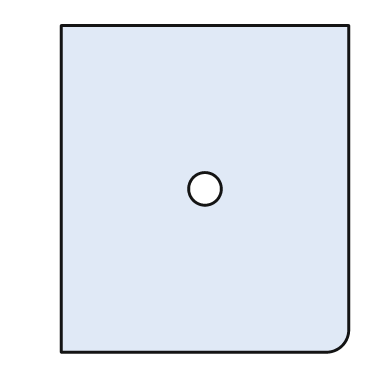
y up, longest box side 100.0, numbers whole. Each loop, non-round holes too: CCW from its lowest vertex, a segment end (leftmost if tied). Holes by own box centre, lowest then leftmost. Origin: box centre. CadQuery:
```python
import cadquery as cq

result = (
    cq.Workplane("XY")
    .moveTo(-44.0, -50.0)
    .lineTo(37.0, -50.0)
    .threePointArc((42.0, -48.0), (44.0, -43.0))
    .lineTo(44.0, 50.0)
    .lineTo(-44.0, 50.0)
    .close()
    .moveTo(0.0, 0.0)
    .circle(5.0)
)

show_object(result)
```